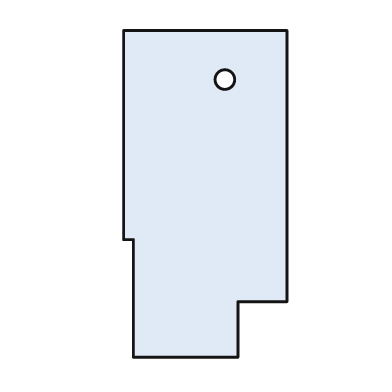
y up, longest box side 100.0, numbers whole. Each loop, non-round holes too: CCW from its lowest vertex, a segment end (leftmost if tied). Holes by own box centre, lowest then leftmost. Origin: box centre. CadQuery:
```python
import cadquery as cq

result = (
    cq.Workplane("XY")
    .moveTo(-22.0, -50.0)
    .lineTo(10.0, -50.0)
    .lineTo(10.0, -33.0)
    .lineTo(25.0, -33.0)
    .lineTo(25.0, 50.0)
    .lineTo(-25.0, 50.0)
    .lineTo(-25.0, -14.0)
    .lineTo(-22.0, -14.0)
    .close()
    .moveTo(6.0, 35.0)
    .circle(3.0)
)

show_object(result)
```